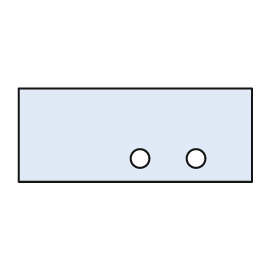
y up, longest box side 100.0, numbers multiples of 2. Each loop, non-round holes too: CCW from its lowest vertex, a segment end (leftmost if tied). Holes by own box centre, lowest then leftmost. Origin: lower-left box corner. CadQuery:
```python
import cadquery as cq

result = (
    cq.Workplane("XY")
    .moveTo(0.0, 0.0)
    .lineTo(100.0, 0.0)
    .lineTo(100.0, 40.0)
    .lineTo(0.0, 40.0)
    .close()
    .moveTo(52.0, 10.0)
    .circle(4.0)
    .moveTo(76.0, 10.0)
    .circle(4.0)
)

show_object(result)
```